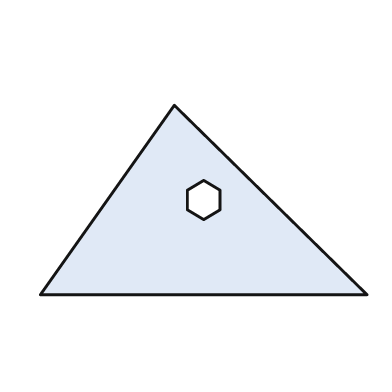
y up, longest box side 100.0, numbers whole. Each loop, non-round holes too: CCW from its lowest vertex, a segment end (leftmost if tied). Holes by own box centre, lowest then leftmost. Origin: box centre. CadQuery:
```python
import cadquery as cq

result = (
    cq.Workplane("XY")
    .moveTo(-50.0, -29.0)
    .lineTo(50.0, -29.0)
    .lineTo(-9.0, 29.0)
    .close()
    .moveTo(0.0, -6.0)
    .lineTo(5.0, -3.0)
    .lineTo(5.0, 3.0)
    .lineTo(0.0, 6.0)
    .lineTo(-5.0, 3.0)
    .lineTo(-5.0, -3.0)
    .close()
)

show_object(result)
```